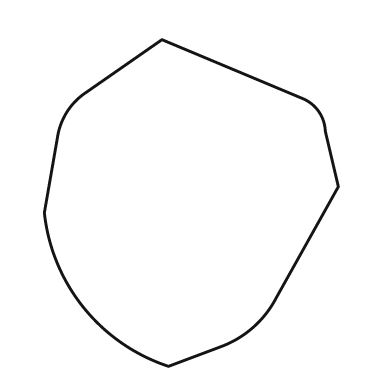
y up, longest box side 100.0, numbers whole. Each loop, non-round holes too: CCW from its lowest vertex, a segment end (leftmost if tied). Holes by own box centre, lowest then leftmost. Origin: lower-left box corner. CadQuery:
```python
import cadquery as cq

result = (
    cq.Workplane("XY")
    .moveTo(38.0, 0.0)
    .lineTo(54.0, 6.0)
    .threePointArc((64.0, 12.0), (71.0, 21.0))
    .lineTo(90.0, 55.0)
    .lineTo(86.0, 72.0)
    .threePointArc((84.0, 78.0), (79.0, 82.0))
    .lineTo(36.0, 100.0)
    .lineTo(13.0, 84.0)
    .threePointArc((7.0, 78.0), (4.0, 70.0))
    .lineTo(0.0, 47.0)
    .threePointArc((12.0, 18.0), (38.0, 0.0))
    .close()
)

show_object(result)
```